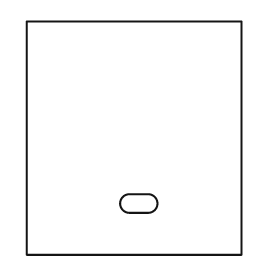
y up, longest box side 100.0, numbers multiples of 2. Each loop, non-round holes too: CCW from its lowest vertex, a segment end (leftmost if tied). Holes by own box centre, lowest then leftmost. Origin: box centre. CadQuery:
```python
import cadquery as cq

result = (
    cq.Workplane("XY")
    .moveTo(-46.0, -50.0)
    .lineTo(46.0, -50.0)
    .lineTo(46.0, 50.0)
    .lineTo(-46.0, 50.0)
    .close()
    .moveTo(-2.0, -32.0)
    .lineTo(6.0, -32.0)
    .threePointArc((10.0, -28.0), (6.0, -24.0))
    .lineTo(-2.0, -24.0)
    .threePointArc((-6.0, -28.0), (-2.0, -32.0))
    .close()
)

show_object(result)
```